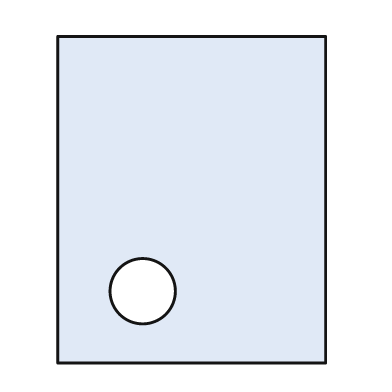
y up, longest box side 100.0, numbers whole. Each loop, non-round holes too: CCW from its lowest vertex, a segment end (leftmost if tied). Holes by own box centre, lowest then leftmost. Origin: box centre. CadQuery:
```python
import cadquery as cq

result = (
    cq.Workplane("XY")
    .moveTo(-41.0, -50.0)
    .lineTo(41.0, -50.0)
    .lineTo(41.0, 50.0)
    .lineTo(-41.0, 50.0)
    .close()
    .moveTo(-15.0, -28.0)
    .circle(10.0)
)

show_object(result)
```